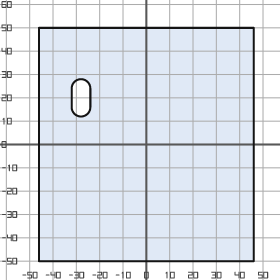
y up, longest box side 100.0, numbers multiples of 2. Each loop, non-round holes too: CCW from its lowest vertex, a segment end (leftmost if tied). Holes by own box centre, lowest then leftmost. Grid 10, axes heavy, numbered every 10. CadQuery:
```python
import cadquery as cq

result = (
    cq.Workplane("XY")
    .moveTo(-46.0, -50.0)
    .lineTo(46.0, -50.0)
    .lineTo(46.0, 50.0)
    .lineTo(-46.0, 50.0)
    .close()
    .moveTo(-32.0, 16.0)
    .threePointArc((-28.0, 12.0), (-24.0, 16.0))
    .lineTo(-24.0, 24.0)
    .threePointArc((-28.0, 28.0), (-32.0, 24.0))
    .close()
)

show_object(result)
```